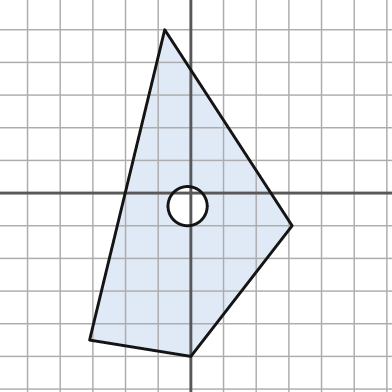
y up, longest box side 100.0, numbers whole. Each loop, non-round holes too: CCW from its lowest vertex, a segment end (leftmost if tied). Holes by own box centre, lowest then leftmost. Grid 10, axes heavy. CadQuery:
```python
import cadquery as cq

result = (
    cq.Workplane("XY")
    .moveTo(0.0, -50.0)
    .lineTo(31.0, -10.0)
    .lineTo(-8.0, 50.0)
    .lineTo(-31.0, -45.0)
    .close()
    .moveTo(-1.0, -4.0)
    .circle(6.0)
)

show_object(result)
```